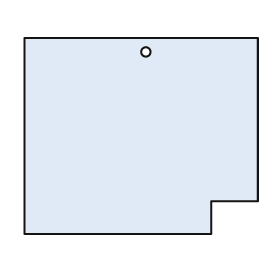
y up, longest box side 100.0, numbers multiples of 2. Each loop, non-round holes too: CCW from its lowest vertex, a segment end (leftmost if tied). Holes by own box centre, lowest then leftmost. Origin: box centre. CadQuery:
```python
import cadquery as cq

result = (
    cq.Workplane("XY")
    .moveTo(-50.0, -42.0)
    .lineTo(30.0, -42.0)
    .lineTo(30.0, -28.0)
    .lineTo(50.0, -28.0)
    .lineTo(50.0, 42.0)
    .lineTo(-50.0, 42.0)
    .close()
    .moveTo(2.0, 36.0)
    .circle(2.0)
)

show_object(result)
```